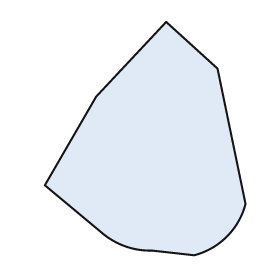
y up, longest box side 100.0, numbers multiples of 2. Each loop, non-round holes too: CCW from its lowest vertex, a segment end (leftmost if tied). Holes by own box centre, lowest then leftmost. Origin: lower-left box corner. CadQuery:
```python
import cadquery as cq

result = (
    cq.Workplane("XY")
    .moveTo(64.0, 0.0)
    .threePointArc((78.0, 8.0), (86.0, 22.0))
    .lineTo(74.0, 80.0)
    .lineTo(52.0, 100.0)
    .lineTo(22.0, 68.0)
    .lineTo(0.0, 30.0)
    .lineTo(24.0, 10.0)
    .threePointArc((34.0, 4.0), (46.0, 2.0))
    .close()
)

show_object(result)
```